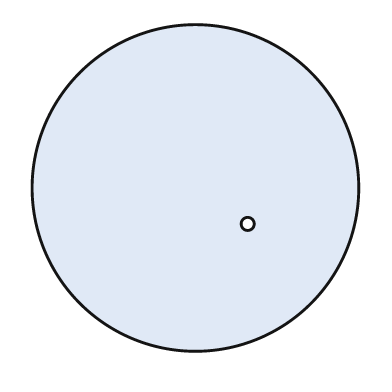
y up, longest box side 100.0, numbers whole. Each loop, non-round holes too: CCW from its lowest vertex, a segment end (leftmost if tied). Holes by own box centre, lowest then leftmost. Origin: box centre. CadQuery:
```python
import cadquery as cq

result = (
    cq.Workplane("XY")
    .moveTo(0.0, 0.0)
    .circle(50.0)
    .moveTo(16.0, -11.0)
    .circle(2.0)
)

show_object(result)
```